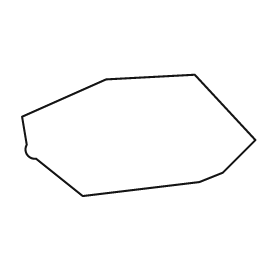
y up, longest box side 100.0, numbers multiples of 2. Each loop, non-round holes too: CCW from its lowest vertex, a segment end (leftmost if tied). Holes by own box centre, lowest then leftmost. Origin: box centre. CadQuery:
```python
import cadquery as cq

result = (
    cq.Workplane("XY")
    .moveTo(-24.0, -26.0)
    .lineTo(26.0, -20.0)
    .lineTo(36.0, -16.0)
    .lineTo(50.0, -2.0)
    .lineTo(24.0, 26.0)
    .lineTo(-14.0, 24.0)
    .lineTo(-50.0, 8.0)
    .lineTo(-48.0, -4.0)
    .threePointArc((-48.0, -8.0), (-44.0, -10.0))
    .close()
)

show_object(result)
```